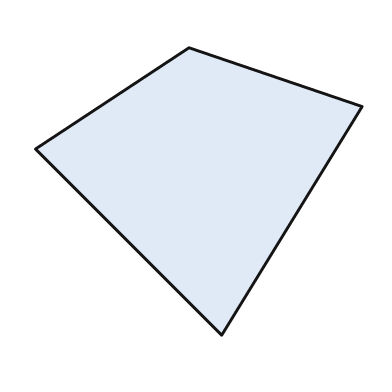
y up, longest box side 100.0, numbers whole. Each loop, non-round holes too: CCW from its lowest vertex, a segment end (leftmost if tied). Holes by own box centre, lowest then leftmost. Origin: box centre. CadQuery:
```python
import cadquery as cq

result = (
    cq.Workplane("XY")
    .moveTo(7.0, -44.0)
    .lineTo(50.0, 26.0)
    .lineTo(-3.0, 44.0)
    .lineTo(-50.0, 13.0)
    .close()
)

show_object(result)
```